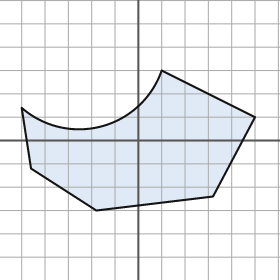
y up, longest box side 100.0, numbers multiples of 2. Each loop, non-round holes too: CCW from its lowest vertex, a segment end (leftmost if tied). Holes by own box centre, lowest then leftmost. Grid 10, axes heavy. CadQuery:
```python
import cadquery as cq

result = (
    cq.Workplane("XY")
    .moveTo(-18.0, -30.0)
    .lineTo(32.0, -24.0)
    .lineTo(50.0, 10.0)
    .lineTo(10.0, 30.0)
    .threePointArc((-16.0, 6.0), (-50.0, 14.0))
    .lineTo(-46.0, -12.0)
    .close()
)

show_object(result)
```